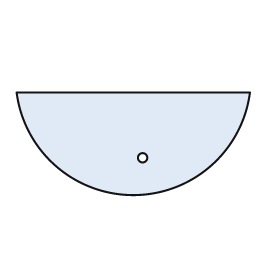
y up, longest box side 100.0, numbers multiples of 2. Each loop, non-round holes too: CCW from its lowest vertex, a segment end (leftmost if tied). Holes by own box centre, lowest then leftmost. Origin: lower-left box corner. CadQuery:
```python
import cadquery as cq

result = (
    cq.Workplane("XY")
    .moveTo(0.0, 44.0)
    .threePointArc((50.0, 0.0), (100.0, 44.0))
    .close()
    .moveTo(54.0, 16.0)
    .circle(2.0)
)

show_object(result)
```